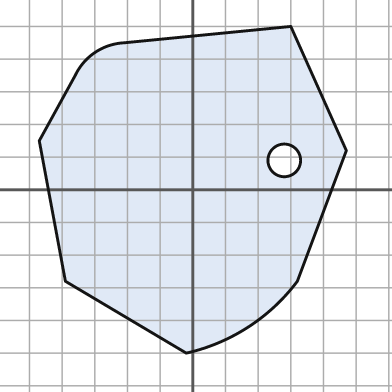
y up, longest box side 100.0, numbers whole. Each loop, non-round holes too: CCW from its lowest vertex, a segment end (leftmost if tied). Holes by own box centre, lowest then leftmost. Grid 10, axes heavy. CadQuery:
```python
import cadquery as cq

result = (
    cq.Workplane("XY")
    .moveTo(-2.0, -50.0)
    .threePointArc((17.0, -42.0), (32.0, -28.0))
    .lineTo(47.0, 12.0)
    .lineTo(30.0, 50.0)
    .lineTo(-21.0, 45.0)
    .threePointArc((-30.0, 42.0), (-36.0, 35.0))
    .lineTo(-47.0, 15.0)
    .lineTo(-39.0, -28.0)
    .close()
    .moveTo(28.0, 9.0)
    .circle(5.0)
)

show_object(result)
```